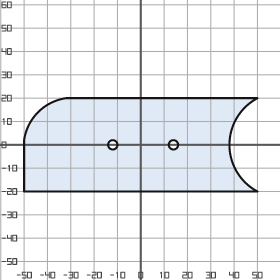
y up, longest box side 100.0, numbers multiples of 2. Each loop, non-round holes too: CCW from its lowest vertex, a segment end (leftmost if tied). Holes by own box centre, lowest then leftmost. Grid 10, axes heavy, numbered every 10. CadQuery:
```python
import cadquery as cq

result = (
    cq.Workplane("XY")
    .moveTo(-50.0, -20.0)
    .lineTo(50.0, -20.0)
    .threePointArc((38.0, 0.0), (50.0, 20.0))
    .lineTo(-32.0, 20.0)
    .threePointArc((-44.0, 14.0), (-50.0, 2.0))
    .close()
    .moveTo(-12.0, 0.0)
    .circle(2.0)
    .moveTo(14.0, 0.0)
    .circle(2.0)
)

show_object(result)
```